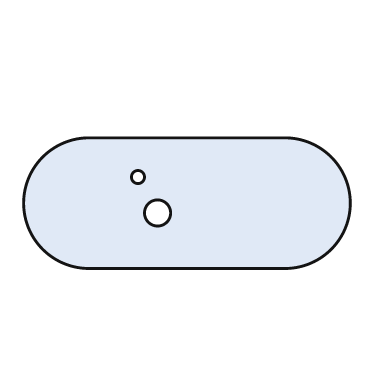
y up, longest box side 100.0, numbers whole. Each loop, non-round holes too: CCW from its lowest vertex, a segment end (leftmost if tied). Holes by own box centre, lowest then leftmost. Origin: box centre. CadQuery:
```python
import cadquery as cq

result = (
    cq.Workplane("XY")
    .moveTo(-30.0, -20.0)
    .lineTo(30.0, -20.0)
    .threePointArc((50.0, 0.0), (30.0, 20.0))
    .lineTo(-30.0, 20.0)
    .threePointArc((-50.0, 0.0), (-30.0, -20.0))
    .close()
    .moveTo(-9.0, -3.0)
    .circle(4.0)
    .moveTo(-15.0, 8.0)
    .circle(2.0)
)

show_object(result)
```